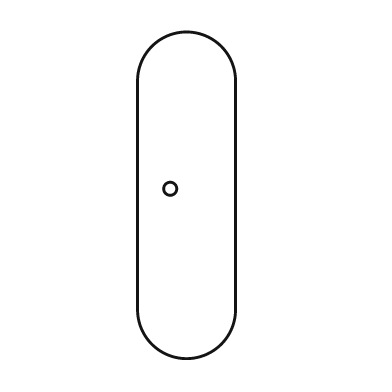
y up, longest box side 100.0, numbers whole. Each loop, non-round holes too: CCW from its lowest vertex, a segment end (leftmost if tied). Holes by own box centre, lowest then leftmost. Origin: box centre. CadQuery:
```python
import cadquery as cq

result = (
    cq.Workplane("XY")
    .moveTo(-15.0, -35.0)
    .threePointArc((0.0, -50.0), (15.0, -35.0))
    .lineTo(15.0, 35.0)
    .threePointArc((0.0, 50.0), (-15.0, 35.0))
    .close()
    .moveTo(-5.0, 2.0)
    .circle(2.0)
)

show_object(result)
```